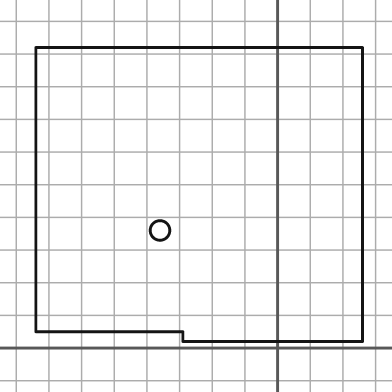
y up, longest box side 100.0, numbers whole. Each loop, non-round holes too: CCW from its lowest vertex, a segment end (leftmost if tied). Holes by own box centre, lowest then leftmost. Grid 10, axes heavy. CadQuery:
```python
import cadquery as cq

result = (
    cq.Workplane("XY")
    .moveTo(-29.0, 2.0)
    .lineTo(26.0, 2.0)
    .lineTo(26.0, 92.0)
    .lineTo(-74.0, 92.0)
    .lineTo(-74.0, 5.0)
    .lineTo(-29.0, 5.0)
    .close()
    .moveTo(-36.0, 36.0)
    .circle(3.0)
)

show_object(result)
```